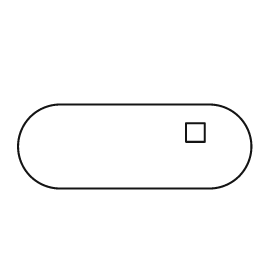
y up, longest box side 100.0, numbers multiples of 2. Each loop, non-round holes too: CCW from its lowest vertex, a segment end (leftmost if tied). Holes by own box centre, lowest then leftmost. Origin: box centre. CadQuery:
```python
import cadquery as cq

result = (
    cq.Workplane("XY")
    .moveTo(-32.0, -18.0)
    .lineTo(32.0, -18.0)
    .threePointArc((50.0, 0.0), (32.0, 18.0))
    .lineTo(-32.0, 18.0)
    .threePointArc((-50.0, 0.0), (-32.0, -18.0))
    .close()
    .moveTo(22.0, 2.0)
    .lineTo(30.0, 2.0)
    .lineTo(30.0, 10.0)
    .lineTo(22.0, 10.0)
    .close()
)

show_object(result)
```